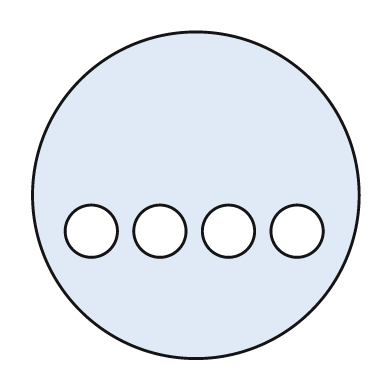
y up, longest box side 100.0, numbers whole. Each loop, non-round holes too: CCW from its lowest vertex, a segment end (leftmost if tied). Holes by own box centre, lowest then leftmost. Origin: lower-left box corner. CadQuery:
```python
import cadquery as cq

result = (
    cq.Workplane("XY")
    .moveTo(50.0, 50.0)
    .circle(50.0)
    .moveTo(18.0, 39.0)
    .circle(8.0)
    .moveTo(39.0, 39.0)
    .circle(8.0)
    .moveTo(60.0, 39.0)
    .circle(8.0)
    .moveTo(81.0, 39.0)
    .circle(8.0)
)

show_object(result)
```